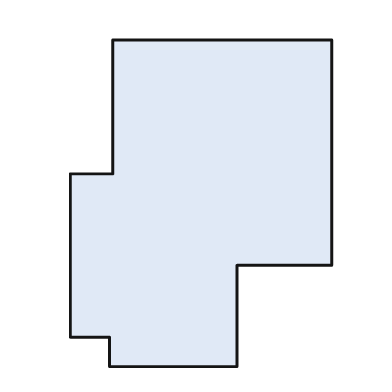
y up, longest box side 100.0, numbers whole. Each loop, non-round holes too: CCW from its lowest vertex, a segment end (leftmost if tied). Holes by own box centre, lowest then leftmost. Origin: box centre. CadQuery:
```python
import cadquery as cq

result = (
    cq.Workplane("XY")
    .moveTo(-28.0, -50.0)
    .lineTo(11.0, -50.0)
    .lineTo(11.0, -19.0)
    .lineTo(40.0, -19.0)
    .lineTo(40.0, 50.0)
    .lineTo(-27.0, 50.0)
    .lineTo(-27.0, 9.0)
    .lineTo(-40.0, 9.0)
    .lineTo(-40.0, -41.0)
    .lineTo(-28.0, -41.0)
    .close()
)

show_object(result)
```